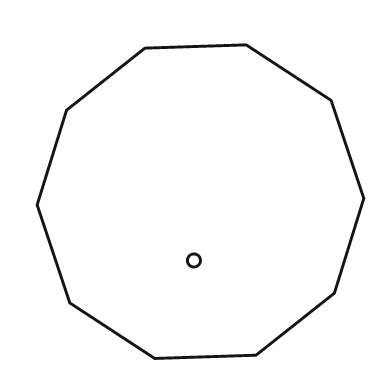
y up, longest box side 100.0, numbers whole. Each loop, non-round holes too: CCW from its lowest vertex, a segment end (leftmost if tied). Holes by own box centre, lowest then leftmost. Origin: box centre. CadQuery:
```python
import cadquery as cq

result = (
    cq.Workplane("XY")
    .moveTo(-14.0, -48.0)
    .lineTo(17.0, -47.0)
    .lineTo(41.0, -28.0)
    .lineTo(50.0, 1.0)
    .lineTo(40.0, 31.0)
    .lineTo(14.0, 48.0)
    .lineTo(-17.0, 47.0)
    .lineTo(-41.0, 28.0)
    .lineTo(-50.0, -1.0)
    .lineTo(-40.0, -31.0)
    .close()
    .moveTo(-2.0, -18.0)
    .circle(2.0)
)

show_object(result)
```